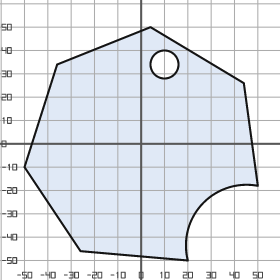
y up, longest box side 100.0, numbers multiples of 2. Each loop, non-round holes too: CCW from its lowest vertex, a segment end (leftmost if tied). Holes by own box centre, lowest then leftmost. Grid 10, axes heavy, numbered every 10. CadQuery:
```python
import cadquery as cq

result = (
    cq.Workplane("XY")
    .moveTo(20.0, -50.0)
    .threePointArc((26.0, -26.0), (50.0, -18.0))
    .lineTo(44.0, 26.0)
    .lineTo(4.0, 50.0)
    .lineTo(-36.0, 34.0)
    .lineTo(-50.0, -10.0)
    .lineTo(-26.0, -46.0)
    .close()
    .moveTo(10.0, 34.0)
    .circle(6.0)
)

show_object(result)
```